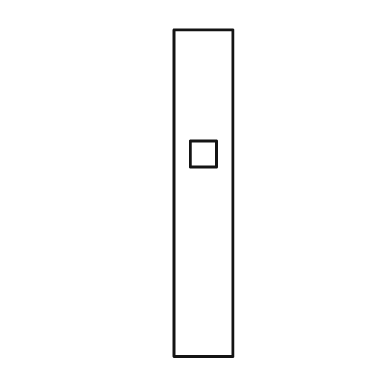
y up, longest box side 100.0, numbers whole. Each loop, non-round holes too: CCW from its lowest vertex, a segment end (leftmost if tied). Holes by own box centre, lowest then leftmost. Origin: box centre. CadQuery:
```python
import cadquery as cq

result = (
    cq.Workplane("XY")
    .moveTo(-9.0, -50.0)
    .lineTo(9.0, -50.0)
    .lineTo(9.0, 50.0)
    .lineTo(-9.0, 50.0)
    .close()
    .moveTo(-4.0, 8.0)
    .lineTo(4.0, 8.0)
    .lineTo(4.0, 16.0)
    .lineTo(-4.0, 16.0)
    .close()
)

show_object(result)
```